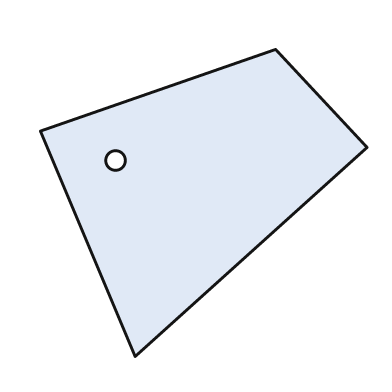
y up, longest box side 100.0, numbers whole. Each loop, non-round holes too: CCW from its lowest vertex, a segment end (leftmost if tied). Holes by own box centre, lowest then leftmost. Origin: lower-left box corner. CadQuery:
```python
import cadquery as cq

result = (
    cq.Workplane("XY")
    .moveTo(29.0, 0.0)
    .lineTo(100.0, 64.0)
    .lineTo(72.0, 94.0)
    .lineTo(0.0, 69.0)
    .close()
    .moveTo(23.0, 60.0)
    .circle(3.0)
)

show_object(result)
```